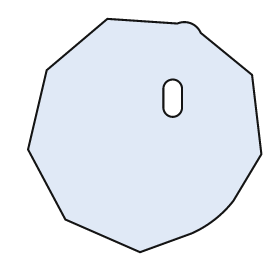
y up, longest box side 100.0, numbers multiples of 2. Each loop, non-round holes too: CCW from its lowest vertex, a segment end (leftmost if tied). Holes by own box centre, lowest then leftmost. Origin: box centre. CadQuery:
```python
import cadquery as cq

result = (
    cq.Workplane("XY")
    .moveTo(-2.0, -50.0)
    .lineTo(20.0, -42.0)
    .threePointArc((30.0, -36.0), (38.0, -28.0))
    .lineTo(50.0, -8.0)
    .lineTo(46.0, 26.0)
    .lineTo(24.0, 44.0)
    .threePointArc((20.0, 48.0), (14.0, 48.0))
    .lineTo(-16.0, 50.0)
    .lineTo(-42.0, 28.0)
    .lineTo(-50.0, -6.0)
    .lineTo(-34.0, -36.0)
    .close()
    .moveTo(8.0, 12.0)
    .threePointArc((12.0, 8.0), (16.0, 12.0))
    .lineTo(16.0, 20.0)
    .threePointArc((12.0, 24.0), (8.0, 20.0))
    .close()
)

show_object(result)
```